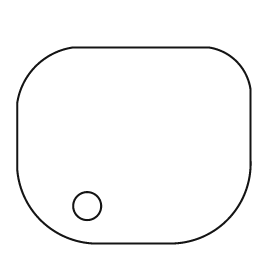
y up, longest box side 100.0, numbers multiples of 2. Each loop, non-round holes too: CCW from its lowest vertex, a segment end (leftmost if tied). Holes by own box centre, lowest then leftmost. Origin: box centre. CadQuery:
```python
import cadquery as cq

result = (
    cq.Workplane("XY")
    .moveTo(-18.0, -42.0)
    .lineTo(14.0, -42.0)
    .threePointArc((40.0, -32.0), (50.0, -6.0))
    .lineTo(50.0, 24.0)
    .threePointArc((44.0, 36.0), (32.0, 42.0))
    .lineTo(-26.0, 42.0)
    .threePointArc((-42.0, 34.0), (-50.0, 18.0))
    .lineTo(-50.0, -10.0)
    .threePointArc((-40.0, -32.0), (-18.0, -42.0))
    .close()
    .moveTo(-20.0, -26.0)
    .circle(6.0)
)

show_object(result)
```